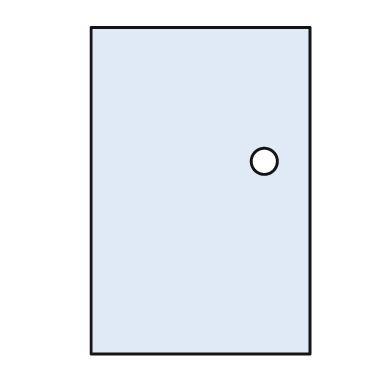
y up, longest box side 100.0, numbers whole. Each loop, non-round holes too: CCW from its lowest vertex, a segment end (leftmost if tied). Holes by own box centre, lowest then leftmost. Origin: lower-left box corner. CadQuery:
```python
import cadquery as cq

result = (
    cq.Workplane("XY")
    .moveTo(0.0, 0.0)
    .lineTo(67.0, 0.0)
    .lineTo(67.0, 100.0)
    .lineTo(0.0, 100.0)
    .close()
    .moveTo(53.0, 59.0)
    .circle(4.0)
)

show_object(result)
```